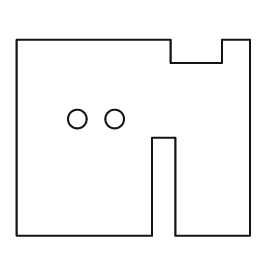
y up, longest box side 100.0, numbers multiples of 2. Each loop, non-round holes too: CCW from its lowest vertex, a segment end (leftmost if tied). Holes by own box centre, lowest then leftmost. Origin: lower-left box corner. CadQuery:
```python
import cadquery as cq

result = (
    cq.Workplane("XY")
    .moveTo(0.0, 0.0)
    .lineTo(58.0, 0.0)
    .lineTo(58.0, 42.0)
    .lineTo(68.0, 42.0)
    .lineTo(68.0, 0.0)
    .lineTo(100.0, 0.0)
    .lineTo(100.0, 84.0)
    .lineTo(88.0, 84.0)
    .lineTo(88.0, 74.0)
    .lineTo(66.0, 74.0)
    .lineTo(66.0, 84.0)
    .lineTo(0.0, 84.0)
    .close()
    .moveTo(26.0, 50.0)
    .circle(4.0)
    .moveTo(42.0, 50.0)
    .circle(4.0)
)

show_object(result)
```